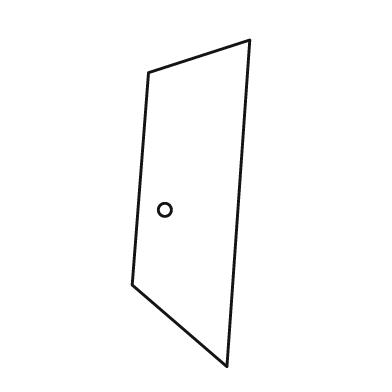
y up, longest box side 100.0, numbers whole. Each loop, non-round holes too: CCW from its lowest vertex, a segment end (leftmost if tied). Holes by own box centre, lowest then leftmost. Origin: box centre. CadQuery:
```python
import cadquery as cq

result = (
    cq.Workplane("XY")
    .moveTo(11.0, -50.0)
    .lineTo(18.0, 50.0)
    .lineTo(-13.0, 40.0)
    .lineTo(-18.0, -25.0)
    .close()
    .moveTo(-8.0, -2.0)
    .circle(2.0)
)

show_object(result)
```